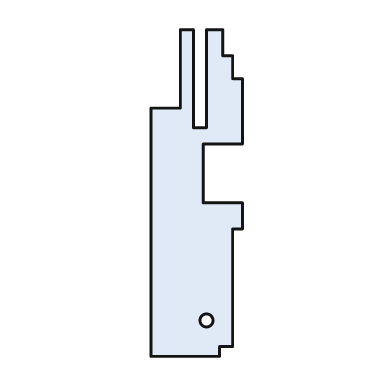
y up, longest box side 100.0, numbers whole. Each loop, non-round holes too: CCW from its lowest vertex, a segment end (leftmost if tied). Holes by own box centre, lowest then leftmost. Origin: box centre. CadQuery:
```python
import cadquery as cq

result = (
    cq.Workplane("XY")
    .moveTo(-14.0, -50.0)
    .lineTo(7.0, -50.0)
    .lineTo(7.0, -47.0)
    .lineTo(11.0, -47.0)
    .lineTo(11.0, -11.0)
    .lineTo(14.0, -11.0)
    .lineTo(14.0, -3.0)
    .lineTo(2.0, -3.0)
    .lineTo(2.0, 15.0)
    .lineTo(14.0, 15.0)
    .lineTo(14.0, 35.0)
    .lineTo(11.0, 35.0)
    .lineTo(11.0, 42.0)
    .lineTo(8.0, 42.0)
    .lineTo(8.0, 50.0)
    .lineTo(3.0, 50.0)
    .lineTo(3.0, 20.0)
    .lineTo(-1.0, 20.0)
    .lineTo(-1.0, 50.0)
    .lineTo(-5.0, 50.0)
    .lineTo(-5.0, 26.0)
    .lineTo(-14.0, 26.0)
    .close()
    .moveTo(3.0, -39.0)
    .circle(2.0)
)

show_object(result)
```